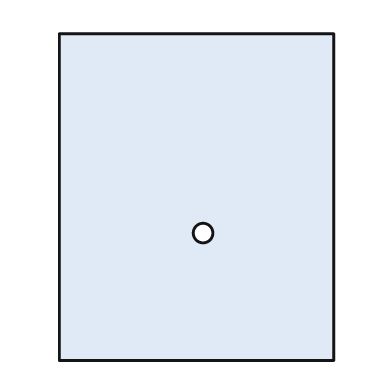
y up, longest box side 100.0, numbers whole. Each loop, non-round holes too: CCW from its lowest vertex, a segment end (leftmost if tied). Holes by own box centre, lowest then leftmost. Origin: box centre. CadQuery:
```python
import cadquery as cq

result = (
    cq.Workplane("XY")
    .moveTo(-42.0, -50.0)
    .lineTo(42.0, -50.0)
    .lineTo(42.0, 50.0)
    .lineTo(-42.0, 50.0)
    .close()
    .moveTo(2.0, -11.0)
    .circle(3.0)
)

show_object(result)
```